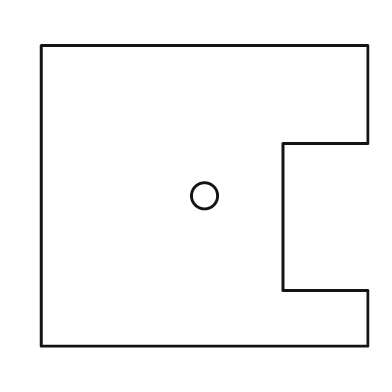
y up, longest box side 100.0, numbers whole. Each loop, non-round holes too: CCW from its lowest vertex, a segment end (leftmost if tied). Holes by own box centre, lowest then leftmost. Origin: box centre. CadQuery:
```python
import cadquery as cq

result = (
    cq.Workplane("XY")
    .moveTo(-50.0, -46.0)
    .lineTo(50.0, -46.0)
    .lineTo(50.0, -29.0)
    .lineTo(24.0, -29.0)
    .lineTo(24.0, 16.0)
    .lineTo(50.0, 16.0)
    .lineTo(50.0, 46.0)
    .lineTo(-50.0, 46.0)
    .close()
    .moveTo(0.0, 0.0)
    .circle(4.0)
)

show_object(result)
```